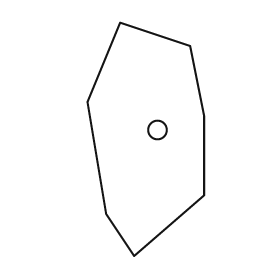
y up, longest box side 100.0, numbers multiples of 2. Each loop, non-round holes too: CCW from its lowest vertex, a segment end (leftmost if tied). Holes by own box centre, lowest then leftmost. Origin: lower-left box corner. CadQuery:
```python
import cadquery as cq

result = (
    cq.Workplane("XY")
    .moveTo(20.0, 0.0)
    .lineTo(50.0, 26.0)
    .lineTo(50.0, 60.0)
    .lineTo(44.0, 90.0)
    .lineTo(14.0, 100.0)
    .lineTo(0.0, 66.0)
    .lineTo(8.0, 18.0)
    .close()
    .moveTo(30.0, 54.0)
    .circle(4.0)
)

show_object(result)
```